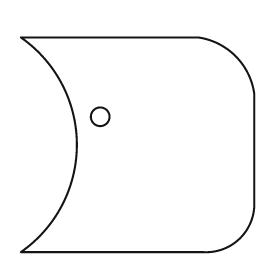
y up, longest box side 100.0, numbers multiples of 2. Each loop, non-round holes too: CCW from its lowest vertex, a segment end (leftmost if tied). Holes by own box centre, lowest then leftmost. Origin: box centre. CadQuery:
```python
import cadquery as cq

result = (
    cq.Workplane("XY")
    .moveTo(-50.0, -46.0)
    .lineTo(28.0, -46.0)
    .threePointArc((44.0, -40.0), (50.0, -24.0))
    .lineTo(50.0, 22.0)
    .threePointArc((42.0, 38.0), (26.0, 46.0))
    .lineTo(-50.0, 46.0)
    .threePointArc((-26.0, 0.0), (-50.0, -46.0))
    .close()
    .moveTo(-16.0, 12.0)
    .circle(4.0)
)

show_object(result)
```